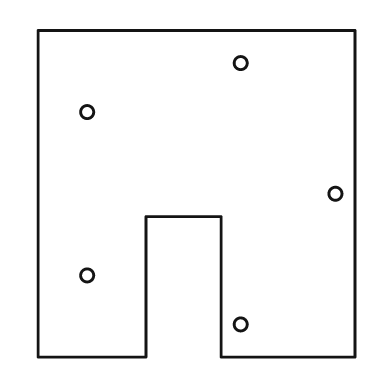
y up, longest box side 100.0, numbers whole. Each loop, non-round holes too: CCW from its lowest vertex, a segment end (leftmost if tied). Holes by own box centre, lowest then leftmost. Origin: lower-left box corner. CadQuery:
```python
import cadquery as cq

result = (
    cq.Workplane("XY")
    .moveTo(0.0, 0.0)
    .lineTo(33.0, 0.0)
    .lineTo(33.0, 43.0)
    .lineTo(56.0, 43.0)
    .lineTo(56.0, 0.0)
    .lineTo(97.0, 0.0)
    .lineTo(97.0, 100.0)
    .lineTo(0.0, 100.0)
    .close()
    .moveTo(62.0, 10.0)
    .circle(2.0)
    .moveTo(15.0, 25.0)
    .circle(2.0)
    .moveTo(91.0, 50.0)
    .circle(2.0)
    .moveTo(15.0, 75.0)
    .circle(2.0)
    .moveTo(62.0, 90.0)
    .circle(2.0)
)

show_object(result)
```